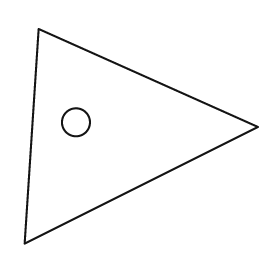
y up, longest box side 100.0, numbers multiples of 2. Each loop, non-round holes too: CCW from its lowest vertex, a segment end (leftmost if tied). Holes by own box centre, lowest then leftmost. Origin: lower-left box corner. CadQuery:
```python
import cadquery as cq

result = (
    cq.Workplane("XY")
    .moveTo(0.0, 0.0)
    .lineTo(100.0, 50.0)
    .lineTo(6.0, 92.0)
    .close()
    .moveTo(22.0, 52.0)
    .circle(6.0)
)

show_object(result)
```